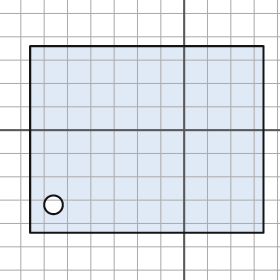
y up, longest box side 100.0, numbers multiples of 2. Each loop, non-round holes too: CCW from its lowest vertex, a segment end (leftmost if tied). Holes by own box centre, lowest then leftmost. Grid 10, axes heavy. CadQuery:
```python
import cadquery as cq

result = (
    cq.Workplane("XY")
    .moveTo(-66.0, -44.0)
    .lineTo(34.0, -44.0)
    .lineTo(34.0, 36.0)
    .lineTo(-66.0, 36.0)
    .close()
    .moveTo(-56.0, -32.0)
    .circle(4.0)
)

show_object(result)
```